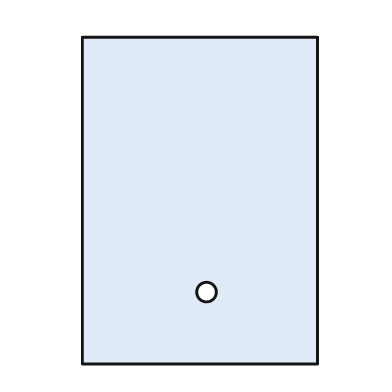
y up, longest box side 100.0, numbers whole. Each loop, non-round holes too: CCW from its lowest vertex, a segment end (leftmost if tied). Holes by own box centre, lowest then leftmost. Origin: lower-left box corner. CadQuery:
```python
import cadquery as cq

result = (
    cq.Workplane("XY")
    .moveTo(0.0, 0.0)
    .lineTo(72.0, 0.0)
    .lineTo(72.0, 100.0)
    .lineTo(0.0, 100.0)
    .close()
    .moveTo(38.0, 22.0)
    .circle(3.0)
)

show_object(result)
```